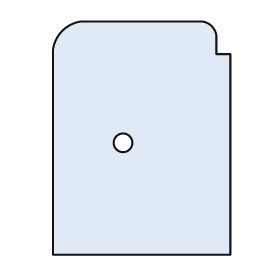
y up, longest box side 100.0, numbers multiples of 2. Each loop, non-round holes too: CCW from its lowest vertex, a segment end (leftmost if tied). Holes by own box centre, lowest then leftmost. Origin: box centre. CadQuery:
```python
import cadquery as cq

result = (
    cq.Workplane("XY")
    .moveTo(-38.0, -50.0)
    .lineTo(38.0, -50.0)
    .lineTo(38.0, 36.0)
    .lineTo(32.0, 36.0)
    .lineTo(32.0, 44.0)
    .threePointArc((30.0, 48.0), (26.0, 50.0))
    .lineTo(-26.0, 50.0)
    .threePointArc((-34.0, 46.0), (-38.0, 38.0))
    .close()
    .moveTo(-8.0, -2.0)
    .circle(4.0)
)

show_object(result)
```